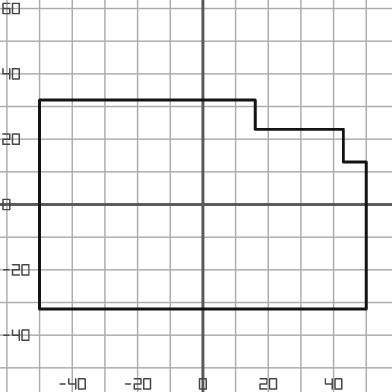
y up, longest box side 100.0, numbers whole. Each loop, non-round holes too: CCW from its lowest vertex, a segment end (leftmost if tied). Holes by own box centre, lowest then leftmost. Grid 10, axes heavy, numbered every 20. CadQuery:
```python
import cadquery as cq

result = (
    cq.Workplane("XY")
    .moveTo(-50.0, -32.0)
    .lineTo(50.0, -32.0)
    .lineTo(50.0, 13.0)
    .lineTo(43.0, 13.0)
    .lineTo(43.0, 23.0)
    .lineTo(16.0, 23.0)
    .lineTo(16.0, 32.0)
    .lineTo(-50.0, 32.0)
    .close()
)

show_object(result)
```